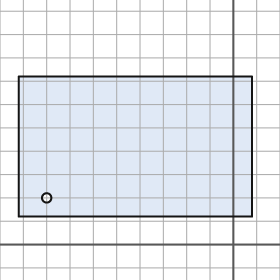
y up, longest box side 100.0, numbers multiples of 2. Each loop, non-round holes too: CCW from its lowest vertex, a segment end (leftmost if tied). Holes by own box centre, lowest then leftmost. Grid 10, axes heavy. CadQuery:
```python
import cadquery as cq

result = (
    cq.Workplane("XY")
    .moveTo(-92.0, 12.0)
    .lineTo(8.0, 12.0)
    .lineTo(8.0, 72.0)
    .lineTo(-92.0, 72.0)
    .close()
    .moveTo(-80.0, 20.0)
    .circle(2.0)
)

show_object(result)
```